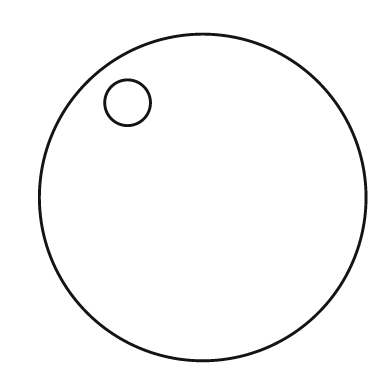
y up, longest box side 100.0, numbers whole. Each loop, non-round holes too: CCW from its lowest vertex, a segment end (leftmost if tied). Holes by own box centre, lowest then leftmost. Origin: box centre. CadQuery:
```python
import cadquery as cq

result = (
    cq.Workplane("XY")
    .moveTo(0.0, 0.0)
    .circle(50.0)
    .moveTo(-23.0, 29.0)
    .circle(7.0)
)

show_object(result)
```